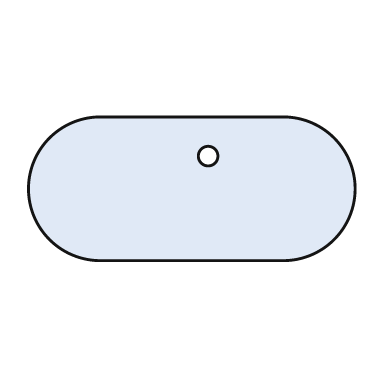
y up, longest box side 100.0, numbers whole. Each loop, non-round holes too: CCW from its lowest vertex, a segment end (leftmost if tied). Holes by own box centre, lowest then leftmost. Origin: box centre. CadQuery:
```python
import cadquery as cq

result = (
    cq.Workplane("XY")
    .moveTo(-28.0, -22.0)
    .lineTo(28.0, -22.0)
    .threePointArc((50.0, 0.0), (28.0, 22.0))
    .lineTo(-28.0, 22.0)
    .threePointArc((-50.0, 0.0), (-28.0, -22.0))
    .close()
    .moveTo(5.0, 10.0)
    .circle(3.0)
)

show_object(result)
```